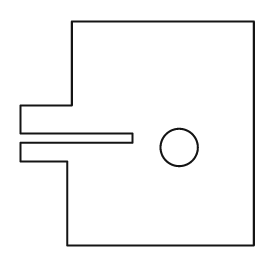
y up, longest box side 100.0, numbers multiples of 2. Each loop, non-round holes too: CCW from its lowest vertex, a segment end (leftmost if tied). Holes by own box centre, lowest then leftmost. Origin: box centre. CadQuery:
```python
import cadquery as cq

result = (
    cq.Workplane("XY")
    .moveTo(-30.0, -48.0)
    .lineTo(50.0, -48.0)
    .lineTo(50.0, 48.0)
    .lineTo(-28.0, 48.0)
    .lineTo(-28.0, 12.0)
    .lineTo(-50.0, 12.0)
    .lineTo(-50.0, 0.0)
    .lineTo(-2.0, 0.0)
    .lineTo(-2.0, -4.0)
    .lineTo(-50.0, -4.0)
    .lineTo(-50.0, -12.0)
    .lineTo(-30.0, -12.0)
    .close()
    .moveTo(18.0, -6.0)
    .circle(8.0)
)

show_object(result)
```